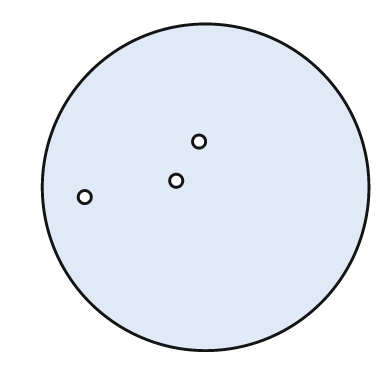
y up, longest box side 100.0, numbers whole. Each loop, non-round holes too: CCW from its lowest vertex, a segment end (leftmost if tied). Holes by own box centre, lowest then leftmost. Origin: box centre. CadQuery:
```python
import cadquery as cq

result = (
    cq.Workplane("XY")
    .moveTo(0.0, 0.0)
    .circle(50.0)
    .moveTo(-37.0, -3.0)
    .circle(2.0)
    .moveTo(-9.0, 2.0)
    .circle(2.0)
    .moveTo(-2.0, 14.0)
    .circle(2.0)
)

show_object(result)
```